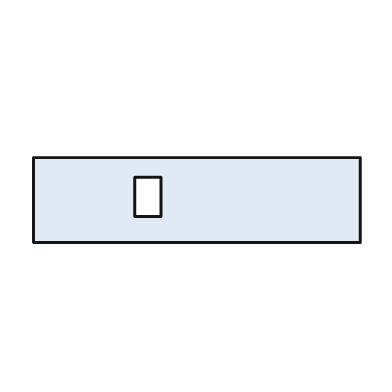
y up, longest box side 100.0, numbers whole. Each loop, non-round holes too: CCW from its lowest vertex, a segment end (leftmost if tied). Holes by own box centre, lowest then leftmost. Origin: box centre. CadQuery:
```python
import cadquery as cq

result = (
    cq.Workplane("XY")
    .moveTo(-50.0, -13.0)
    .lineTo(50.0, -13.0)
    .lineTo(50.0, 13.0)
    .lineTo(-50.0, 13.0)
    .close()
    .moveTo(-19.0, -5.0)
    .lineTo(-11.0, -5.0)
    .lineTo(-11.0, 7.0)
    .lineTo(-19.0, 7.0)
    .close()
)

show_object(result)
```